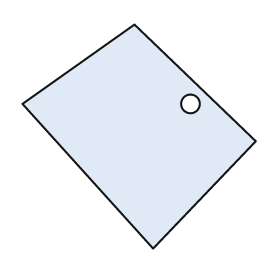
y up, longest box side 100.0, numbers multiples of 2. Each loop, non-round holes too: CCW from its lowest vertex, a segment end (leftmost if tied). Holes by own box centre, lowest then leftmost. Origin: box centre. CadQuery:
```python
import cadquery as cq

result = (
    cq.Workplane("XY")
    .moveTo(6.0, -48.0)
    .lineTo(50.0, -2.0)
    .lineTo(-2.0, 48.0)
    .lineTo(-50.0, 14.0)
    .close()
    .moveTo(22.0, 14.0)
    .circle(4.0)
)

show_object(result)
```